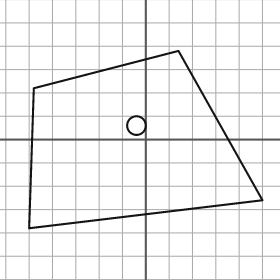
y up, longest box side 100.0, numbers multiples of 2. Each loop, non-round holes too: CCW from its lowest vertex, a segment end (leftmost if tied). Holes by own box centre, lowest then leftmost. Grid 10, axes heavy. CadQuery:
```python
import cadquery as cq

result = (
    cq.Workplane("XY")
    .moveTo(-50.0, -38.0)
    .lineTo(50.0, -26.0)
    .lineTo(14.0, 38.0)
    .lineTo(-48.0, 22.0)
    .close()
    .moveTo(-4.0, 6.0)
    .circle(4.0)
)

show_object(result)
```